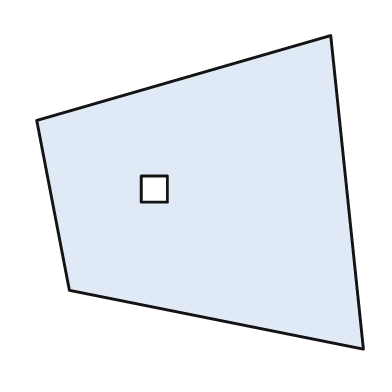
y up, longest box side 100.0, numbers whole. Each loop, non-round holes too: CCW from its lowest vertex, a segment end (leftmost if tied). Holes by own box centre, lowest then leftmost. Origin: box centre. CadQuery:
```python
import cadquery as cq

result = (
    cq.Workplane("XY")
    .moveTo(50.0, -48.0)
    .lineTo(40.0, 48.0)
    .lineTo(-50.0, 22.0)
    .lineTo(-40.0, -30.0)
    .close()
    .moveTo(-18.0, -3.0)
    .lineTo(-10.0, -3.0)
    .lineTo(-10.0, 5.0)
    .lineTo(-18.0, 5.0)
    .close()
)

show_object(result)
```